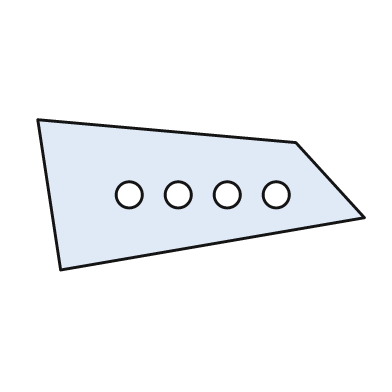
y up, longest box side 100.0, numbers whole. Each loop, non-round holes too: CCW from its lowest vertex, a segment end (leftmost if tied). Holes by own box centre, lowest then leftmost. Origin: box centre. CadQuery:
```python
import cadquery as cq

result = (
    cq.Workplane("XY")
    .moveTo(-43.0, -23.0)
    .lineTo(50.0, -7.0)
    .lineTo(29.0, 16.0)
    .lineTo(-50.0, 23.0)
    .close()
    .moveTo(-22.0, 0.0)
    .circle(4.0)
    .moveTo(-7.0, 0.0)
    .circle(4.0)
    .moveTo(8.0, 0.0)
    .circle(4.0)
    .moveTo(23.0, 0.0)
    .circle(4.0)
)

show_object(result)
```